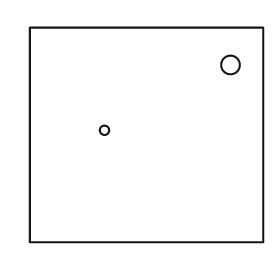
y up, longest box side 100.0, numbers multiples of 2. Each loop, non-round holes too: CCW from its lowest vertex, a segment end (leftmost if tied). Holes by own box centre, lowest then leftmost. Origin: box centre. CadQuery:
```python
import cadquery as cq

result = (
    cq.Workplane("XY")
    .moveTo(-50.0, -46.0)
    .lineTo(50.0, -46.0)
    .lineTo(50.0, 46.0)
    .lineTo(-50.0, 46.0)
    .close()
    .moveTo(-18.0, 2.0)
    .circle(2.0)
    .moveTo(36.0, 30.0)
    .circle(4.0)
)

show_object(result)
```